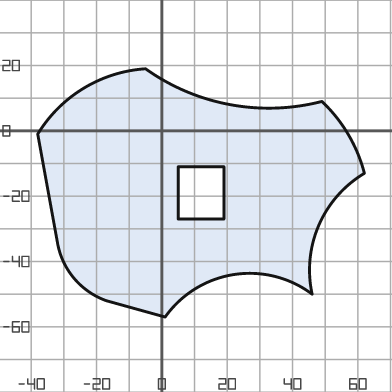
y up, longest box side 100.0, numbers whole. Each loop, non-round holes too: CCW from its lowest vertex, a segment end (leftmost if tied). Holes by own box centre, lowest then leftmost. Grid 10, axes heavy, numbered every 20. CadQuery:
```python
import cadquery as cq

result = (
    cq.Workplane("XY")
    .moveTo(1.0, -57.0)
    .threePointArc((22.0, -44.0), (46.0, -50.0))
    .threePointArc((48.0, -29.0), (62.0, -13.0))
    .threePointArc((57.0, -1.0), (49.0, 9.0))
    .threePointArc((21.0, 8.0), (-5.0, 19.0))
    .threePointArc((-24.0, 13.0), (-38.0, -1.0))
    .lineTo(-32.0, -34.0)
    .threePointArc((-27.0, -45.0), (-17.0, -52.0))
    .close()
    .moveTo(5.0, -27.0)
    .lineTo(19.0, -27.0)
    .lineTo(19.0, -11.0)
    .lineTo(5.0, -11.0)
    .close()
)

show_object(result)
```